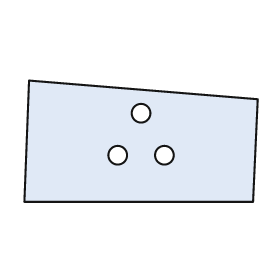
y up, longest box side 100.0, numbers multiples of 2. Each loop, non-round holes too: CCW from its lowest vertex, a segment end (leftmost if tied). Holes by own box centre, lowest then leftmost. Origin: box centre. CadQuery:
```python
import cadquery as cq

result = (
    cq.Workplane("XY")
    .moveTo(-50.0, -26.0)
    .lineTo(48.0, -26.0)
    .lineTo(50.0, 18.0)
    .lineTo(-48.0, 26.0)
    .close()
    .moveTo(-10.0, -6.0)
    .circle(4.0)
    .moveTo(10.0, -6.0)
    .circle(4.0)
    .moveTo(0.0, 12.0)
    .circle(4.0)
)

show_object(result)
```